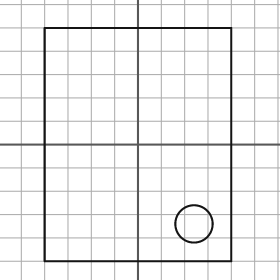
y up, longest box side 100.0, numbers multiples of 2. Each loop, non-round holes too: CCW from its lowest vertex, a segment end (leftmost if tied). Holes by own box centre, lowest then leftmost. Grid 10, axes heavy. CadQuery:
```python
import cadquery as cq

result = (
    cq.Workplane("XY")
    .moveTo(-40.0, -50.0)
    .lineTo(40.0, -50.0)
    .lineTo(40.0, 50.0)
    .lineTo(-40.0, 50.0)
    .close()
    .moveTo(24.0, -34.0)
    .circle(8.0)
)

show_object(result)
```